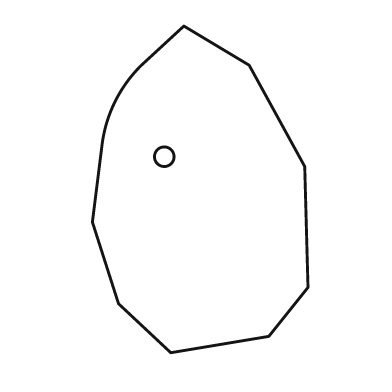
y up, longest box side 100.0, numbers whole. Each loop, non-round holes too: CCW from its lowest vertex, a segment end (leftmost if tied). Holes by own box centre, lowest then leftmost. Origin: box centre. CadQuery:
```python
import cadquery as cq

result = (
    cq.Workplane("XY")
    .moveTo(-9.0, -50.0)
    .lineTo(21.0, -45.0)
    .lineTo(33.0, -30.0)
    .lineTo(32.0, 7.0)
    .lineTo(15.0, 38.0)
    .lineTo(-5.0, 50.0)
    .lineTo(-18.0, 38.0)
    .threePointArc((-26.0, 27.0), (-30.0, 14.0))
    .lineTo(-33.0, -10.0)
    .lineTo(-25.0, -35.0)
    .close()
    .moveTo(-11.0, 10.0)
    .circle(3.0)
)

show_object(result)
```